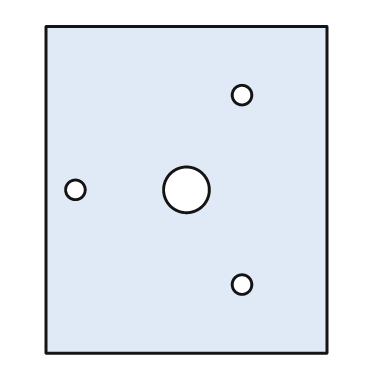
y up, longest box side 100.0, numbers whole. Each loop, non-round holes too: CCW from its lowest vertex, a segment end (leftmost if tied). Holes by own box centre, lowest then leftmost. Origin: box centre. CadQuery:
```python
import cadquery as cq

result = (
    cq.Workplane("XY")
    .moveTo(-43.0, -50.0)
    .lineTo(43.0, -50.0)
    .lineTo(43.0, 50.0)
    .lineTo(-43.0, 50.0)
    .close()
    .moveTo(17.0, -29.0)
    .circle(3.0)
    .moveTo(-34.0, 0.0)
    .circle(3.0)
    .moveTo(0.0, 0.0)
    .circle(7.0)
    .moveTo(17.0, 29.0)
    .circle(3.0)
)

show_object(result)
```